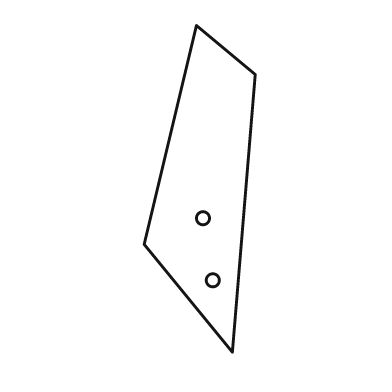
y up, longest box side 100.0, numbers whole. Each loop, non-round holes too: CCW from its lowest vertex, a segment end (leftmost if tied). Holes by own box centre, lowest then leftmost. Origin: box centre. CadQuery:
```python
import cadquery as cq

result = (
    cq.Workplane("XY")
    .moveTo(10.0, -50.0)
    .lineTo(17.0, 35.0)
    .lineTo(-1.0, 50.0)
    .lineTo(-17.0, -17.0)
    .close()
    .moveTo(4.0, -28.0)
    .circle(2.0)
    .moveTo(1.0, -9.0)
    .circle(2.0)
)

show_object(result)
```